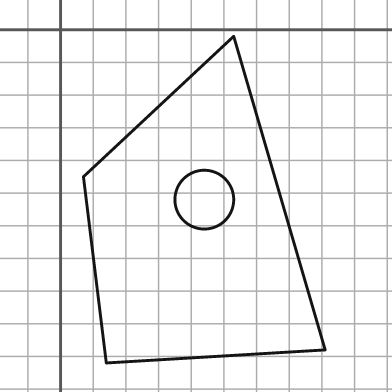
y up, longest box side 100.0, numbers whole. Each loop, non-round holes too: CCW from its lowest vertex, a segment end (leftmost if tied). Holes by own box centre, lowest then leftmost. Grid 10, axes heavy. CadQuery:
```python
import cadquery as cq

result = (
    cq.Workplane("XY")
    .moveTo(14.0, -102.0)
    .lineTo(81.0, -98.0)
    .lineTo(53.0, -2.0)
    .lineTo(7.0, -45.0)
    .close()
    .moveTo(44.0, -52.0)
    .circle(9.0)
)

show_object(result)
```